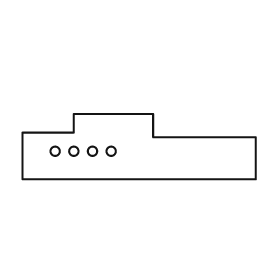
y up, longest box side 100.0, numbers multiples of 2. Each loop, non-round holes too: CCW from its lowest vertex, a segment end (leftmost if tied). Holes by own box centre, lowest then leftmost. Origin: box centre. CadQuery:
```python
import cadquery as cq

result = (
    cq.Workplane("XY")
    .moveTo(-50.0, -14.0)
    .lineTo(50.0, -14.0)
    .lineTo(50.0, 4.0)
    .lineTo(6.0, 4.0)
    .lineTo(6.0, 14.0)
    .lineTo(-28.0, 14.0)
    .lineTo(-28.0, 6.0)
    .lineTo(-50.0, 6.0)
    .close()
    .moveTo(-36.0, -2.0)
    .circle(2.0)
    .moveTo(-28.0, -2.0)
    .circle(2.0)
    .moveTo(-20.0, -2.0)
    .circle(2.0)
    .moveTo(-12.0, -2.0)
    .circle(2.0)
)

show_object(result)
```